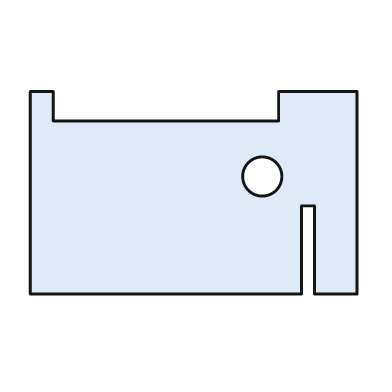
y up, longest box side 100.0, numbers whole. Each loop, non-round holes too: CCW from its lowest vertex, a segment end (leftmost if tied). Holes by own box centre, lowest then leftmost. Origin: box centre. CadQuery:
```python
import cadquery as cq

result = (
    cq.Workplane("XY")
    .moveTo(-50.0, -31.0)
    .lineTo(33.0, -31.0)
    .lineTo(33.0, -4.0)
    .lineTo(37.0, -4.0)
    .lineTo(37.0, -31.0)
    .lineTo(50.0, -31.0)
    .lineTo(50.0, 31.0)
    .lineTo(26.0, 31.0)
    .lineTo(26.0, 22.0)
    .lineTo(-43.0, 22.0)
    .lineTo(-43.0, 31.0)
    .lineTo(-50.0, 31.0)
    .close()
    .moveTo(21.0, 5.0)
    .circle(6.0)
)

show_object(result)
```